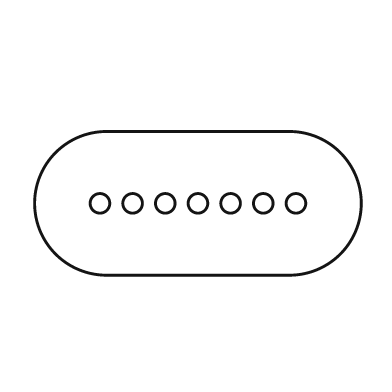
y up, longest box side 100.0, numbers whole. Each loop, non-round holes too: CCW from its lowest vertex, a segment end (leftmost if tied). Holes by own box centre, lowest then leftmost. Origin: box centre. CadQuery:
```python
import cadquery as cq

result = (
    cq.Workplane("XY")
    .moveTo(-28.0, -22.0)
    .lineTo(28.0, -22.0)
    .threePointArc((50.0, 0.0), (28.0, 22.0))
    .lineTo(-28.0, 22.0)
    .threePointArc((-50.0, 0.0), (-28.0, -22.0))
    .close()
    .moveTo(-30.0, 0.0)
    .circle(3.0)
    .moveTo(-20.0, 0.0)
    .circle(3.0)
    .moveTo(-10.0, 0.0)
    .circle(3.0)
    .moveTo(0.0, 0.0)
    .circle(3.0)
    .moveTo(10.0, 0.0)
    .circle(3.0)
    .moveTo(20.0, 0.0)
    .circle(3.0)
    .moveTo(30.0, 0.0)
    .circle(3.0)
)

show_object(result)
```